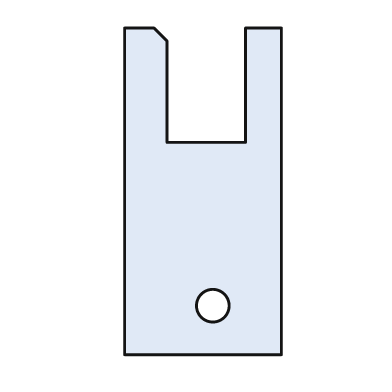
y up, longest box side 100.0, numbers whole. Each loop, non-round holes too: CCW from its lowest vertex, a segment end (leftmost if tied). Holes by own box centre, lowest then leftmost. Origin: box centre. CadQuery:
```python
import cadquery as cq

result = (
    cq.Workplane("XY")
    .moveTo(-24.0, -50.0)
    .lineTo(24.0, -50.0)
    .lineTo(24.0, 50.0)
    .lineTo(13.0, 50.0)
    .lineTo(13.0, 15.0)
    .lineTo(-11.0, 15.0)
    .lineTo(-11.0, 46.0)
    .lineTo(-15.0, 50.0)
    .lineTo(-24.0, 50.0)
    .close()
    .moveTo(3.0, -35.0)
    .circle(5.0)
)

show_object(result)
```